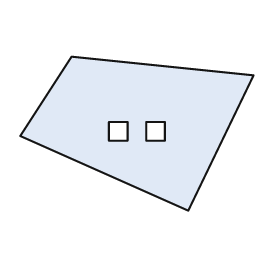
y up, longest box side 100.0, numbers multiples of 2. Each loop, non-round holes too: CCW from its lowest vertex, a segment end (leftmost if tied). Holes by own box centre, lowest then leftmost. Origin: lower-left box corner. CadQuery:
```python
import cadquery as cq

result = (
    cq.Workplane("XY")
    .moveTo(72.0, 0.0)
    .lineTo(100.0, 58.0)
    .lineTo(22.0, 66.0)
    .lineTo(0.0, 32.0)
    .close()
    .moveTo(38.0, 30.0)
    .lineTo(46.0, 30.0)
    .lineTo(46.0, 38.0)
    .lineTo(38.0, 38.0)
    .close()
    .moveTo(54.0, 30.0)
    .lineTo(62.0, 30.0)
    .lineTo(62.0, 38.0)
    .lineTo(54.0, 38.0)
    .close()
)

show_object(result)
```